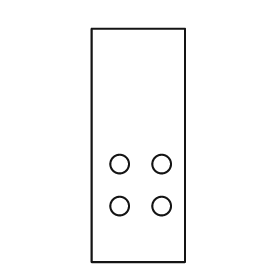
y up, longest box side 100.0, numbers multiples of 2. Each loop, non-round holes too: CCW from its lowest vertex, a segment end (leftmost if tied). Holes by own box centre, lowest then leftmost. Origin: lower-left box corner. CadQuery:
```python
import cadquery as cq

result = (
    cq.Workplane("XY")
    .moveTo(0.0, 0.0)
    .lineTo(40.0, 0.0)
    .lineTo(40.0, 100.0)
    .lineTo(0.0, 100.0)
    .close()
    .moveTo(12.0, 24.0)
    .circle(4.0)
    .moveTo(30.0, 24.0)
    .circle(4.0)
    .moveTo(12.0, 42.0)
    .circle(4.0)
    .moveTo(30.0, 42.0)
    .circle(4.0)
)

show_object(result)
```